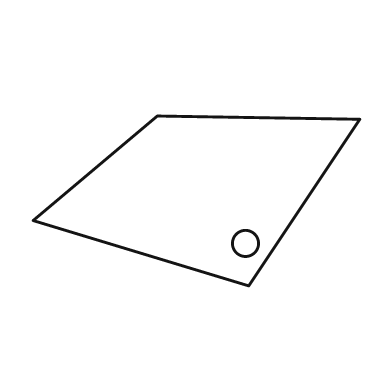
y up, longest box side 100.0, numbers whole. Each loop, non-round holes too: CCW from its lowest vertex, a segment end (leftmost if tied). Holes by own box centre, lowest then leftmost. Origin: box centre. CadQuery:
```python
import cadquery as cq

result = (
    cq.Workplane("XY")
    .moveTo(16.0, -26.0)
    .lineTo(50.0, 25.0)
    .lineTo(-12.0, 26.0)
    .lineTo(-50.0, -6.0)
    .close()
    .moveTo(15.0, -13.0)
    .circle(4.0)
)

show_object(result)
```